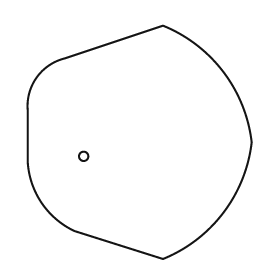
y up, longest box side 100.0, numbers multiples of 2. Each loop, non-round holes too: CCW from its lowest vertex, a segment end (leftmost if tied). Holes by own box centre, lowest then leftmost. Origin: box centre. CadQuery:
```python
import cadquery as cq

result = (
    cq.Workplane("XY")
    .moveTo(10.0, -50.0)
    .threePointArc((36.0, -30.0), (48.0, 0.0))
    .threePointArc((36.0, 30.0), (10.0, 50.0))
    .lineTo(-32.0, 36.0)
    .threePointArc((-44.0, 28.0), (-48.0, 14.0))
    .lineTo(-48.0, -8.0)
    .threePointArc((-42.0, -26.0), (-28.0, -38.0))
    .close()
    .moveTo(-24.0, -6.0)
    .circle(2.0)
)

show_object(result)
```